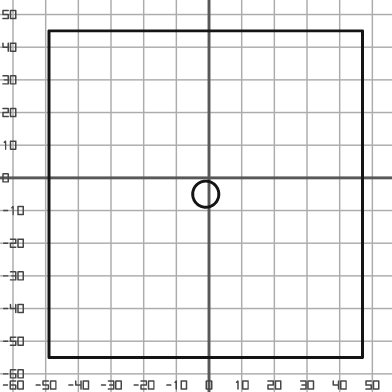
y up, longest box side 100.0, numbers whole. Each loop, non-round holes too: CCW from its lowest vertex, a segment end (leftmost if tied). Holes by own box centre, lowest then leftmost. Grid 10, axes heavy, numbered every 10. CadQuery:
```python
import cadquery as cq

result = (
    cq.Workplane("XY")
    .moveTo(-49.0, -55.0)
    .lineTo(47.0, -55.0)
    .lineTo(47.0, 45.0)
    .lineTo(-49.0, 45.0)
    .close()
    .moveTo(-1.0, -5.0)
    .circle(4.0)
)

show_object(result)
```